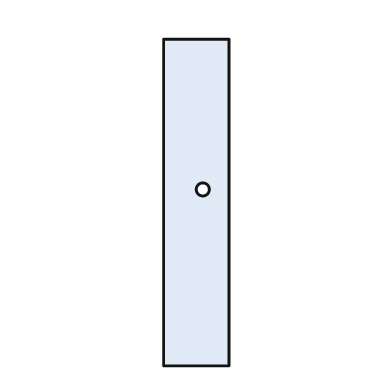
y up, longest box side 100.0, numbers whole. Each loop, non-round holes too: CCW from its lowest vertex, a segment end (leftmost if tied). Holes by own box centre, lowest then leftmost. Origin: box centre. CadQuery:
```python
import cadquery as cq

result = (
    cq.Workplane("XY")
    .moveTo(-10.0, -50.0)
    .lineTo(10.0, -50.0)
    .lineTo(10.0, 50.0)
    .lineTo(-10.0, 50.0)
    .close()
    .moveTo(2.0, 4.0)
    .circle(2.0)
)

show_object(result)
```